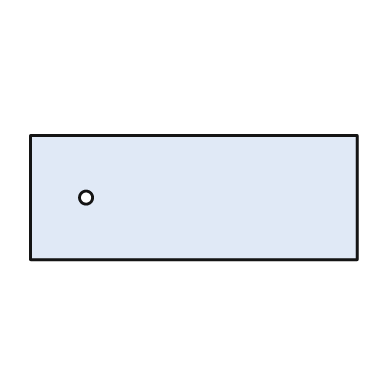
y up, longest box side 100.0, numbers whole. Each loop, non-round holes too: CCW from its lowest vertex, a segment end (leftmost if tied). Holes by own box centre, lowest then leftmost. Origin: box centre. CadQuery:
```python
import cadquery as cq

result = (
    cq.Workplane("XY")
    .moveTo(-50.0, -19.0)
    .lineTo(50.0, -19.0)
    .lineTo(50.0, 19.0)
    .lineTo(-50.0, 19.0)
    .close()
    .moveTo(-33.0, 0.0)
    .circle(2.0)
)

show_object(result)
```